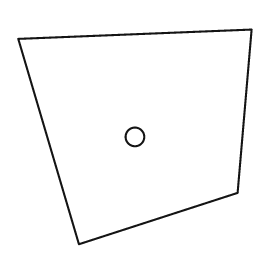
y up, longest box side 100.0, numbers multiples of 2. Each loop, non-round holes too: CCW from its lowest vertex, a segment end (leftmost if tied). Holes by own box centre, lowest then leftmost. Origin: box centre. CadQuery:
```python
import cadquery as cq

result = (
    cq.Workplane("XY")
    .moveTo(-24.0, -46.0)
    .lineTo(44.0, -24.0)
    .lineTo(50.0, 46.0)
    .lineTo(-50.0, 42.0)
    .close()
    .moveTo(0.0, 0.0)
    .circle(4.0)
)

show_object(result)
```